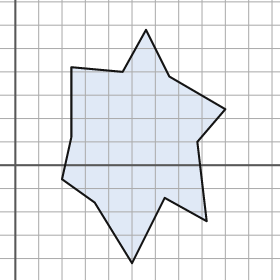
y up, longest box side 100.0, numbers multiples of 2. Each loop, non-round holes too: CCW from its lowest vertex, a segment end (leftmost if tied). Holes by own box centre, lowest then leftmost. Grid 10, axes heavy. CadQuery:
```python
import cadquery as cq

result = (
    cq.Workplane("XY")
    .moveTo(50.0, -42.0)
    .lineTo(64.0, -14.0)
    .lineTo(82.0, -24.0)
    .lineTo(78.0, 10.0)
    .lineTo(90.0, 24.0)
    .lineTo(66.0, 38.0)
    .lineTo(56.0, 58.0)
    .lineTo(46.0, 40.0)
    .lineTo(24.0, 42.0)
    .lineTo(24.0, 12.0)
    .lineTo(20.0, -6.0)
    .lineTo(34.0, -16.0)
    .close()
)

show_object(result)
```